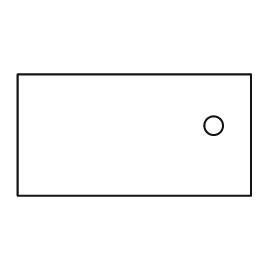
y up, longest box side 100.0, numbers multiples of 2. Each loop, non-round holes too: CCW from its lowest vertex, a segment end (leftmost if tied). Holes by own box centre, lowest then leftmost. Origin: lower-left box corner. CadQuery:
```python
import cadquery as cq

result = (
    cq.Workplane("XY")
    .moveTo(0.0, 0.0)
    .lineTo(100.0, 0.0)
    .lineTo(100.0, 52.0)
    .lineTo(0.0, 52.0)
    .close()
    .moveTo(84.0, 30.0)
    .circle(4.0)
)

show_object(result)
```